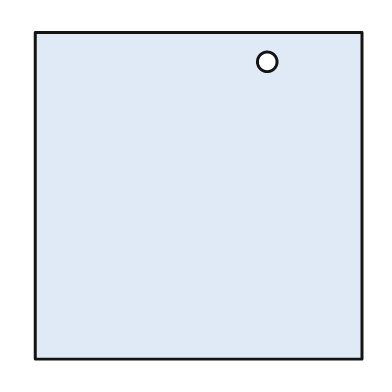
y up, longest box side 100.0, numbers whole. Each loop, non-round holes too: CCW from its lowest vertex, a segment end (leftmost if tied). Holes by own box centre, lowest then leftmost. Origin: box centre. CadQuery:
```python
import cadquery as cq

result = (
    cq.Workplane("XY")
    .moveTo(-50.0, -50.0)
    .lineTo(50.0, -50.0)
    .lineTo(50.0, 50.0)
    .lineTo(-50.0, 50.0)
    .close()
    .moveTo(21.0, 41.0)
    .circle(3.0)
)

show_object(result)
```